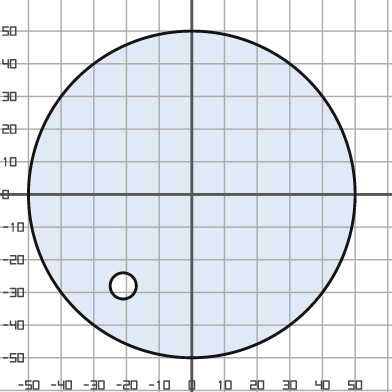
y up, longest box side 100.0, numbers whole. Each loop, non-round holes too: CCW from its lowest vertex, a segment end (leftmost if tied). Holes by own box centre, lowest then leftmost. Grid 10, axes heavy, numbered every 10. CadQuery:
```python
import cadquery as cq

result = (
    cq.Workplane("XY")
    .moveTo(0.0, 0.0)
    .circle(50.0)
    .moveTo(-21.0, -28.0)
    .circle(4.0)
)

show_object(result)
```